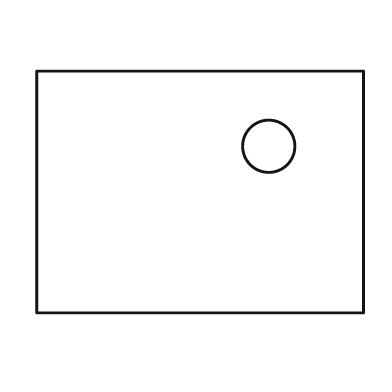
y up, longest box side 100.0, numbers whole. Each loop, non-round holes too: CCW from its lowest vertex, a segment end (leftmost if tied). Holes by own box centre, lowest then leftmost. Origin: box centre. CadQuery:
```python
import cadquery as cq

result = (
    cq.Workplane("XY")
    .moveTo(-50.0, -37.0)
    .lineTo(50.0, -37.0)
    .lineTo(50.0, 37.0)
    .lineTo(-50.0, 37.0)
    .close()
    .moveTo(21.0, 14.0)
    .circle(8.0)
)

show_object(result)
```